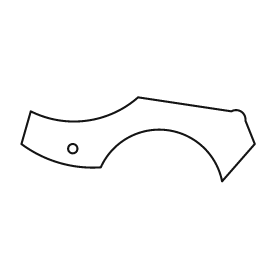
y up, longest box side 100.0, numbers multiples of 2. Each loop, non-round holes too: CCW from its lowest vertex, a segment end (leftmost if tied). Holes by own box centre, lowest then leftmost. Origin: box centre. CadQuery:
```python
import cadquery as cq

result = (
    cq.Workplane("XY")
    .moveTo(36.0, -18.0)
    .lineTo(50.0, -2.0)
    .lineTo(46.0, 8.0)
    .threePointArc((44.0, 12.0), (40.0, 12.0))
    .lineTo(0.0, 18.0)
    .threePointArc((-22.0, 8.0), (-46.0, 12.0))
    .lineTo(-50.0, -2.0)
    .threePointArc((-34.0, -10.0), (-16.0, -12.0))
    .threePointArc((12.0, 4.0), (36.0, -18.0))
    .close()
    .moveTo(-28.0, -4.0)
    .circle(2.0)
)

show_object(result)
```